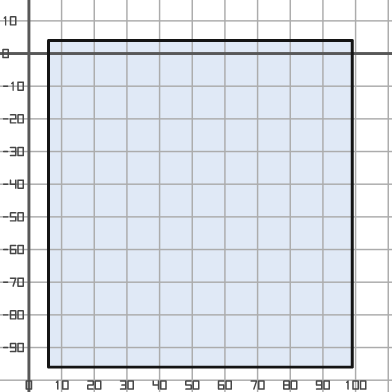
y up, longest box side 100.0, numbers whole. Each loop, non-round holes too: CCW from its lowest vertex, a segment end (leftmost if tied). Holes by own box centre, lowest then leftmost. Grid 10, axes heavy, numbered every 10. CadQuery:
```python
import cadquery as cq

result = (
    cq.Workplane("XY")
    .moveTo(6.0, -96.0)
    .lineTo(99.0, -96.0)
    .lineTo(99.0, 4.0)
    .lineTo(6.0, 4.0)
    .close()
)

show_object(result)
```